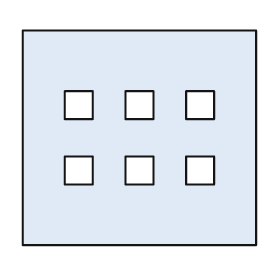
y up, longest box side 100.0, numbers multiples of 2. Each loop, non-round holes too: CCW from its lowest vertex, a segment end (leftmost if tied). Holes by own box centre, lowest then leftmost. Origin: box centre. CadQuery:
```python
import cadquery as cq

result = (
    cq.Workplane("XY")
    .moveTo(-50.0, -46.0)
    .lineTo(50.0, -46.0)
    .lineTo(50.0, 46.0)
    .lineTo(-50.0, 46.0)
    .close()
    .moveTo(-32.0, -20.0)
    .lineTo(-20.0, -20.0)
    .lineTo(-20.0, -8.0)
    .lineTo(-32.0, -8.0)
    .close()
    .moveTo(-6.0, -20.0)
    .lineTo(6.0, -20.0)
    .lineTo(6.0, -8.0)
    .lineTo(-6.0, -8.0)
    .close()
    .moveTo(20.0, -20.0)
    .lineTo(32.0, -20.0)
    .lineTo(32.0, -8.0)
    .lineTo(20.0, -8.0)
    .close()
    .moveTo(-32.0, 8.0)
    .lineTo(-20.0, 8.0)
    .lineTo(-20.0, 20.0)
    .lineTo(-32.0, 20.0)
    .close()
    .moveTo(-6.0, 8.0)
    .lineTo(6.0, 8.0)
    .lineTo(6.0, 20.0)
    .lineTo(-6.0, 20.0)
    .close()
    .moveTo(20.0, 8.0)
    .lineTo(32.0, 8.0)
    .lineTo(32.0, 20.0)
    .lineTo(20.0, 20.0)
    .close()
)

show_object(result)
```